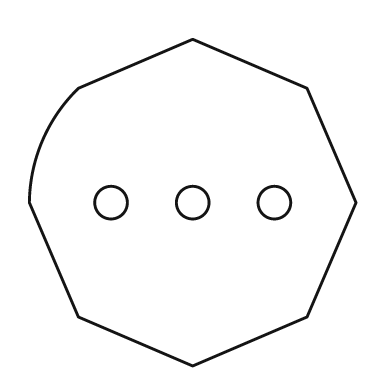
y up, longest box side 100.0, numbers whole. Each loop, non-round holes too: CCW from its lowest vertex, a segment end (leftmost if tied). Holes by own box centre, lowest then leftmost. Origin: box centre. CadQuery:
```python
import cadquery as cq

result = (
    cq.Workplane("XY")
    .moveTo(0.0, -50.0)
    .lineTo(35.0, -35.0)
    .lineTo(50.0, 0.0)
    .lineTo(35.0, 35.0)
    .lineTo(0.0, 50.0)
    .lineTo(-35.0, 35.0)
    .threePointArc((-46.0, 19.0), (-50.0, 0.0))
    .lineTo(-35.0, -35.0)
    .close()
    .moveTo(-25.0, 0.0)
    .circle(5.0)
    .moveTo(0.0, 0.0)
    .circle(5.0)
    .moveTo(25.0, 0.0)
    .circle(5.0)
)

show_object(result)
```